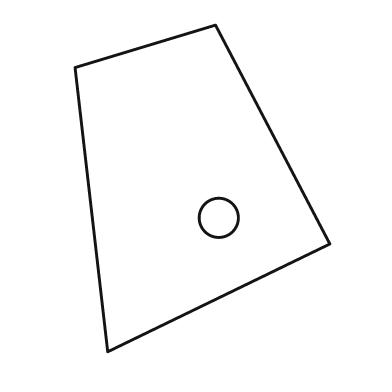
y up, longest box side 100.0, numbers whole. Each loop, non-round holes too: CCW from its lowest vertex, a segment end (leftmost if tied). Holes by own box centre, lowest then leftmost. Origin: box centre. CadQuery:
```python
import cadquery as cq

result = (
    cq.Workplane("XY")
    .moveTo(-29.0, -50.0)
    .lineTo(39.0, -17.0)
    .lineTo(4.0, 50.0)
    .lineTo(-39.0, 37.0)
    .close()
    .moveTo(5.0, -9.0)
    .circle(6.0)
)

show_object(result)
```